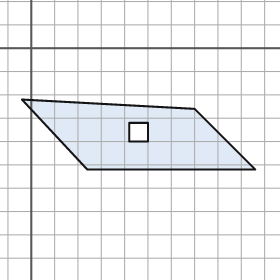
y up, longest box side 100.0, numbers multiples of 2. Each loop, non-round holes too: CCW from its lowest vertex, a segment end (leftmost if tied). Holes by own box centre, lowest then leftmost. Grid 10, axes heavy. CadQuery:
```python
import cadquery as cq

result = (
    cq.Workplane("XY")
    .moveTo(24.0, -52.0)
    .lineTo(96.0, -52.0)
    .lineTo(70.0, -26.0)
    .lineTo(-4.0, -22.0)
    .close()
    .moveTo(42.0, -40.0)
    .lineTo(50.0, -40.0)
    .lineTo(50.0, -32.0)
    .lineTo(42.0, -32.0)
    .close()
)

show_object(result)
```